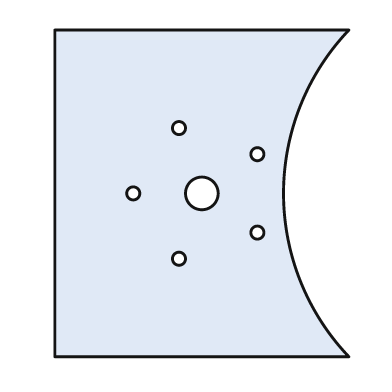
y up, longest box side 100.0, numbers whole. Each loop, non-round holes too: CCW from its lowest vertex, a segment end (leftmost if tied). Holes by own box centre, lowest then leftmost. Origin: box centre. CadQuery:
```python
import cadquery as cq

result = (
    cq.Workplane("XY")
    .moveTo(-45.0, -50.0)
    .lineTo(45.0, -50.0)
    .threePointArc((25.0, 0.0), (45.0, 50.0))
    .lineTo(-45.0, 50.0)
    .close()
    .moveTo(-7.0, -20.0)
    .circle(2.0)
    .moveTo(17.0, -12.0)
    .circle(2.0)
    .moveTo(-21.0, 0.0)
    .circle(2.0)
    .moveTo(0.0, 0.0)
    .circle(5.0)
    .moveTo(17.0, 12.0)
    .circle(2.0)
    .moveTo(-7.0, 20.0)
    .circle(2.0)
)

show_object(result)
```